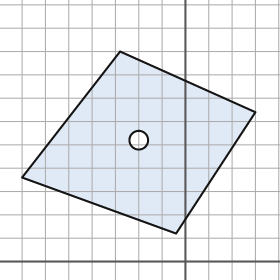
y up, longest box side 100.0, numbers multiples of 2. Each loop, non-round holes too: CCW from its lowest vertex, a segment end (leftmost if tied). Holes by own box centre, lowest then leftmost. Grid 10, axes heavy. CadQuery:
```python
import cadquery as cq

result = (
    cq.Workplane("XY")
    .moveTo(-4.0, 12.0)
    .lineTo(30.0, 64.0)
    .lineTo(-28.0, 90.0)
    .lineTo(-70.0, 36.0)
    .close()
    .moveTo(-20.0, 52.0)
    .circle(4.0)
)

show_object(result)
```